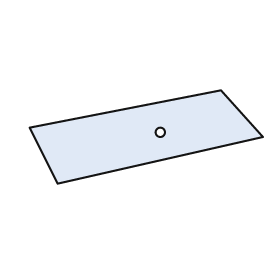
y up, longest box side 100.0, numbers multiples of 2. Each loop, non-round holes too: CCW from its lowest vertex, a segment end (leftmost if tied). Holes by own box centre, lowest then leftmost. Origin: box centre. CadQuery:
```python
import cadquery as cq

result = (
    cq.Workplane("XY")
    .moveTo(-38.0, -20.0)
    .lineTo(50.0, 0.0)
    .lineTo(32.0, 20.0)
    .lineTo(-50.0, 4.0)
    .close()
    .moveTo(6.0, 2.0)
    .circle(2.0)
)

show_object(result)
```